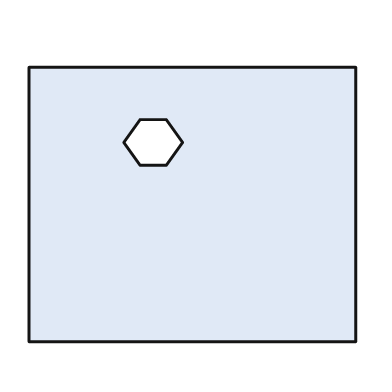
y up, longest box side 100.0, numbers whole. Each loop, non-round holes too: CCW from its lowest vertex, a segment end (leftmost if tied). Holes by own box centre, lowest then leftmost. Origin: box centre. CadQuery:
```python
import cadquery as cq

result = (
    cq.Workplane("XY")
    .moveTo(-50.0, -42.0)
    .lineTo(50.0, -42.0)
    .lineTo(50.0, 42.0)
    .lineTo(-50.0, 42.0)
    .close()
    .moveTo(-16.0, 12.0)
    .lineTo(-8.0, 12.0)
    .lineTo(-3.0, 19.0)
    .lineTo(-8.0, 26.0)
    .lineTo(-16.0, 26.0)
    .lineTo(-21.0, 19.0)
    .close()
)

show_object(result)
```